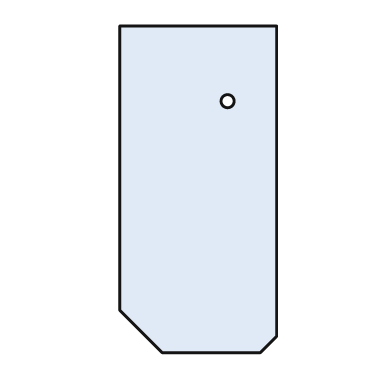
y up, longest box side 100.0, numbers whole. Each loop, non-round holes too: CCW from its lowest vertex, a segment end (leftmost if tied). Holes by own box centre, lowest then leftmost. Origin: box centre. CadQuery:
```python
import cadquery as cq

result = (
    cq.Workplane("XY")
    .moveTo(-11.0, -50.0)
    .lineTo(19.0, -50.0)
    .lineTo(24.0, -45.0)
    .lineTo(24.0, 50.0)
    .lineTo(-24.0, 50.0)
    .lineTo(-24.0, -37.0)
    .close()
    .moveTo(9.0, 27.0)
    .circle(2.0)
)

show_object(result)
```